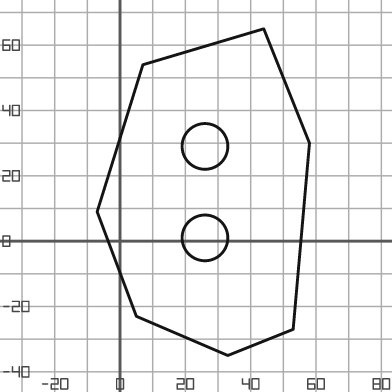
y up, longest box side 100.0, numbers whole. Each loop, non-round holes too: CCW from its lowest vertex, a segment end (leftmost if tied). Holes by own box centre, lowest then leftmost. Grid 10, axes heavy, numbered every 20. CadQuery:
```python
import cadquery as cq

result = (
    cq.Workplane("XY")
    .moveTo(33.0, -35.0)
    .lineTo(53.0, -27.0)
    .lineTo(58.0, 30.0)
    .lineTo(44.0, 65.0)
    .lineTo(7.0, 54.0)
    .lineTo(-7.0, 9.0)
    .lineTo(5.0, -23.0)
    .close()
    .moveTo(26.0, 1.0)
    .circle(7.0)
    .moveTo(26.0, 29.0)
    .circle(7.0)
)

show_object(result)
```